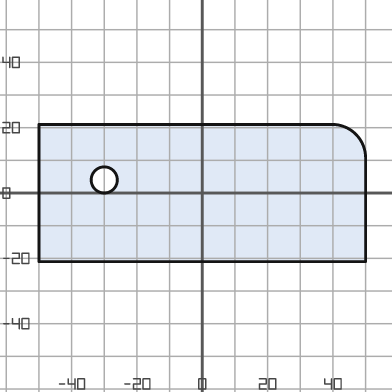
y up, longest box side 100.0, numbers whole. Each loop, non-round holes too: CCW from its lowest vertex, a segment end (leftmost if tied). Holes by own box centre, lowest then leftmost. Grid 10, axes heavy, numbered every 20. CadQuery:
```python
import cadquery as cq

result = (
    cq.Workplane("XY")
    .moveTo(-50.0, -21.0)
    .lineTo(50.0, -21.0)
    .lineTo(50.0, 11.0)
    .threePointArc((47.0, 18.0), (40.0, 21.0))
    .lineTo(-50.0, 21.0)
    .close()
    .moveTo(-30.0, 4.0)
    .circle(4.0)
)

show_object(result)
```